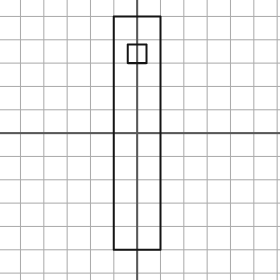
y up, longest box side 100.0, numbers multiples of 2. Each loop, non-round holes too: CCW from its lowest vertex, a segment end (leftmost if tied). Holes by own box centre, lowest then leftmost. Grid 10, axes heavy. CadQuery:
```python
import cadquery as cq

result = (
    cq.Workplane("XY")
    .moveTo(-10.0, -50.0)
    .lineTo(10.0, -50.0)
    .lineTo(10.0, 50.0)
    .lineTo(-10.0, 50.0)
    .close()
    .moveTo(-4.0, 30.0)
    .lineTo(4.0, 30.0)
    .lineTo(4.0, 38.0)
    .lineTo(-4.0, 38.0)
    .close()
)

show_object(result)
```